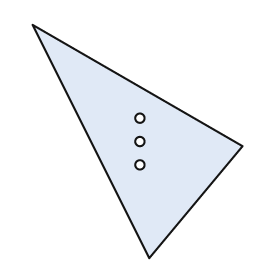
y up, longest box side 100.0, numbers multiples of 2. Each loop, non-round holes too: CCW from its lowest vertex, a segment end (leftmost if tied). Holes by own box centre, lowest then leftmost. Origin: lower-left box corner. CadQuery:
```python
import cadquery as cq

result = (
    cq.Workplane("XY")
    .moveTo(50.0, 0.0)
    .lineTo(90.0, 48.0)
    .lineTo(0.0, 100.0)
    .close()
    .moveTo(46.0, 40.0)
    .circle(2.0)
    .moveTo(46.0, 50.0)
    .circle(2.0)
    .moveTo(46.0, 60.0)
    .circle(2.0)
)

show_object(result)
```